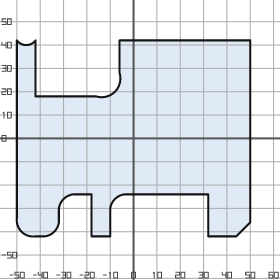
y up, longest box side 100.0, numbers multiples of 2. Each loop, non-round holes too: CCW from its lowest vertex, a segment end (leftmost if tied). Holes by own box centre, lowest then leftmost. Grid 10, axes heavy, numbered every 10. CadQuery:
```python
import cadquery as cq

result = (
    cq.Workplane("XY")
    .moveTo(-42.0, -42.0)
    .lineTo(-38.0, -42.0)
    .threePointArc((-34.0, -40.0), (-32.0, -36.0))
    .lineTo(-32.0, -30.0)
    .threePointArc((-30.0, -26.0), (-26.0, -24.0))
    .lineTo(-18.0, -24.0)
    .lineTo(-18.0, -42.0)
    .lineTo(-10.0, -42.0)
    .lineTo(-10.0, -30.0)
    .threePointArc((-8.0, -26.0), (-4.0, -24.0))
    .lineTo(32.0, -24.0)
    .lineTo(32.0, -42.0)
    .lineTo(44.0, -42.0)
    .lineTo(50.0, -36.0)
    .lineTo(50.0, 42.0)
    .lineTo(-6.0, 42.0)
    .lineTo(-6.0, 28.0)
    .threePointArc((-8.0, 20.0), (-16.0, 18.0))
    .lineTo(-42.0, 18.0)
    .lineTo(-42.0, 42.0)
    .threePointArc((-46.0, 40.0), (-50.0, 42.0))
    .lineTo(-50.0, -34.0)
    .threePointArc((-48.0, -40.0), (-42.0, -42.0))
    .close()
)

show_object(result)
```